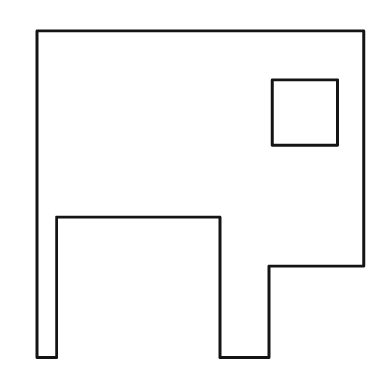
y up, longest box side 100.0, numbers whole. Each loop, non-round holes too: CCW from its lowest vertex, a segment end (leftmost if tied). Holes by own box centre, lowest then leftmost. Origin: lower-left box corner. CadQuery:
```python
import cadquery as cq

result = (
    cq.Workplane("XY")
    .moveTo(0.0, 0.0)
    .lineTo(6.0, 0.0)
    .lineTo(6.0, 43.0)
    .lineTo(56.0, 43.0)
    .lineTo(56.0, 0.0)
    .lineTo(71.0, 0.0)
    .lineTo(71.0, 28.0)
    .lineTo(100.0, 28.0)
    .lineTo(100.0, 100.0)
    .lineTo(0.0, 100.0)
    .close()
    .moveTo(72.0, 65.0)
    .lineTo(92.0, 65.0)
    .lineTo(92.0, 85.0)
    .lineTo(72.0, 85.0)
    .close()
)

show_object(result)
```